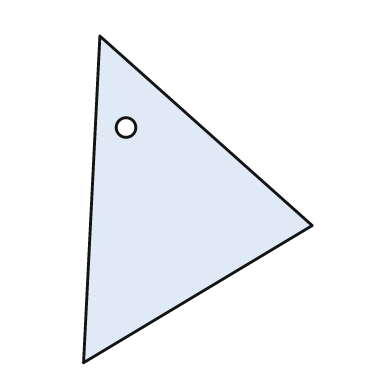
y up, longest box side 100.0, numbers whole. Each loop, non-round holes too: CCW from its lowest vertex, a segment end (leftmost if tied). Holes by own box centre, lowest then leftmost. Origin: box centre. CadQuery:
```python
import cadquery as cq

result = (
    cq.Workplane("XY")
    .moveTo(-35.0, -50.0)
    .lineTo(35.0, -8.0)
    .lineTo(-30.0, 50.0)
    .close()
    .moveTo(-22.0, 22.0)
    .circle(3.0)
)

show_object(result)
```